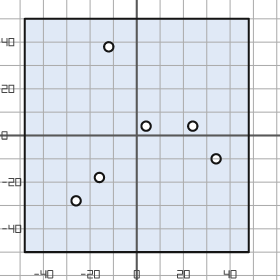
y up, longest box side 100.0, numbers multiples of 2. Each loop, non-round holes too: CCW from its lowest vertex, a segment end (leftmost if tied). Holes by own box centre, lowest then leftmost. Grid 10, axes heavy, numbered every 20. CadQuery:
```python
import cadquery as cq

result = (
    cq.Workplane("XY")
    .moveTo(-48.0, -50.0)
    .lineTo(48.0, -50.0)
    .lineTo(48.0, 50.0)
    .lineTo(-48.0, 50.0)
    .close()
    .moveTo(-26.0, -28.0)
    .circle(2.0)
    .moveTo(-16.0, -18.0)
    .circle(2.0)
    .moveTo(34.0, -10.0)
    .circle(2.0)
    .moveTo(4.0, 4.0)
    .circle(2.0)
    .moveTo(24.0, 4.0)
    .circle(2.0)
    .moveTo(-12.0, 38.0)
    .circle(2.0)
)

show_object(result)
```